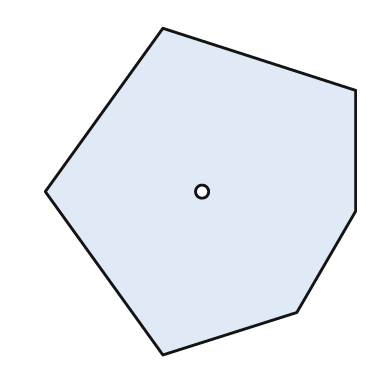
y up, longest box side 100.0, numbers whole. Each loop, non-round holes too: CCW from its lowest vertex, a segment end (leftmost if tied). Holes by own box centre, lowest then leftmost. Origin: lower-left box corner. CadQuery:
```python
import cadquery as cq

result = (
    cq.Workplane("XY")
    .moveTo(36.0, 0.0)
    .lineTo(77.0, 13.0)
    .lineTo(95.0, 44.0)
    .lineTo(95.0, 81.0)
    .lineTo(36.0, 100.0)
    .lineTo(0.0, 50.0)
    .close()
    .moveTo(48.0, 50.0)
    .circle(2.0)
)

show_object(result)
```